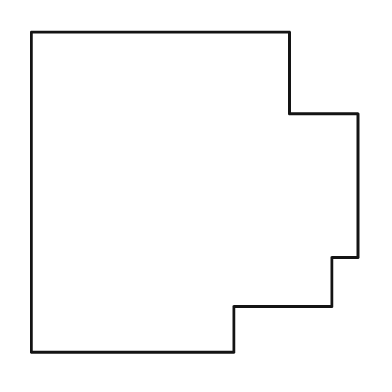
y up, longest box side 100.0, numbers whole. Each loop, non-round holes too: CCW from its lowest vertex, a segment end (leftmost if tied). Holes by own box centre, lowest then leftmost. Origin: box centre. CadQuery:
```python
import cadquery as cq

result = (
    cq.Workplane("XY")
    .moveTo(-50.0, -49.0)
    .lineTo(12.0, -49.0)
    .lineTo(12.0, -35.0)
    .lineTo(42.0, -35.0)
    .lineTo(42.0, -20.0)
    .lineTo(50.0, -20.0)
    .lineTo(50.0, 24.0)
    .lineTo(29.0, 24.0)
    .lineTo(29.0, 49.0)
    .lineTo(-50.0, 49.0)
    .close()
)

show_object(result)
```